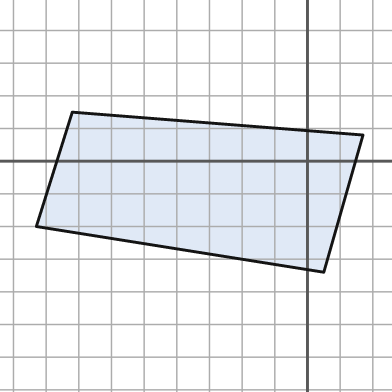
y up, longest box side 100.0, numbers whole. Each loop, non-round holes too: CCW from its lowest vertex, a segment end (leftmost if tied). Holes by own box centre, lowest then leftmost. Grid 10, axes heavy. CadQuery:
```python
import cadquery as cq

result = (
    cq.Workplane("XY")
    .moveTo(5.0, -34.0)
    .lineTo(17.0, 8.0)
    .lineTo(-72.0, 15.0)
    .lineTo(-83.0, -20.0)
    .close()
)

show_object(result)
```